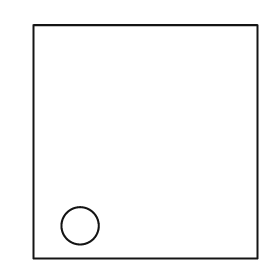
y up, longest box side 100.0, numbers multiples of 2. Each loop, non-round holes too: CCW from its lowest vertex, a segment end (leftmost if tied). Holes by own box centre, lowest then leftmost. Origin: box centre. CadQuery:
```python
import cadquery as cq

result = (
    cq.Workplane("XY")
    .moveTo(-48.0, -50.0)
    .lineTo(48.0, -50.0)
    .lineTo(48.0, 50.0)
    .lineTo(-48.0, 50.0)
    .close()
    .moveTo(-28.0, -36.0)
    .circle(8.0)
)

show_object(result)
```